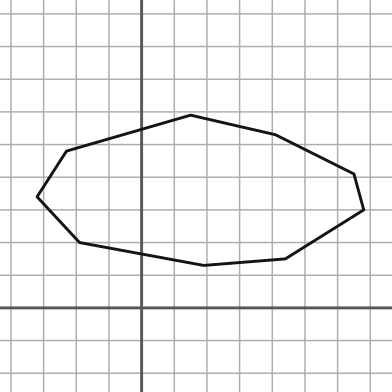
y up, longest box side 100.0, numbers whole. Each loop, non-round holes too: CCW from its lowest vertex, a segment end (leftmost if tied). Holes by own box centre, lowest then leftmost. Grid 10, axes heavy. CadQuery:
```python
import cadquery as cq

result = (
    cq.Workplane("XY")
    .moveTo(19.0, 13.0)
    .lineTo(44.0, 15.0)
    .lineTo(68.0, 30.0)
    .lineTo(65.0, 41.0)
    .lineTo(41.0, 53.0)
    .lineTo(15.0, 59.0)
    .lineTo(-23.0, 48.0)
    .lineTo(-32.0, 34.0)
    .lineTo(-19.0, 20.0)
    .close()
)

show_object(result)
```